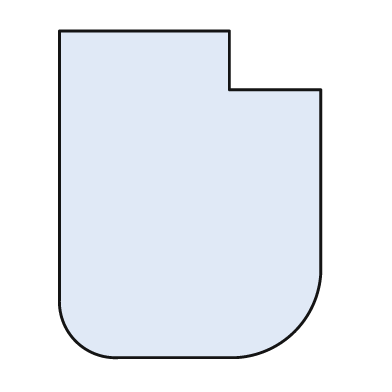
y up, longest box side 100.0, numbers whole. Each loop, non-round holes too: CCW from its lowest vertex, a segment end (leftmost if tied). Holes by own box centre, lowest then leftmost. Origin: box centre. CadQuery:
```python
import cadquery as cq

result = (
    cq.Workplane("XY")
    .moveTo(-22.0, -50.0)
    .lineTo(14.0, -50.0)
    .threePointArc((32.0, -42.0), (40.0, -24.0))
    .lineTo(40.0, 32.0)
    .lineTo(12.0, 32.0)
    .lineTo(12.0, 50.0)
    .lineTo(-40.0, 50.0)
    .lineTo(-40.0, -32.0)
    .threePointArc((-35.0, -45.0), (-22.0, -50.0))
    .close()
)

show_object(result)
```